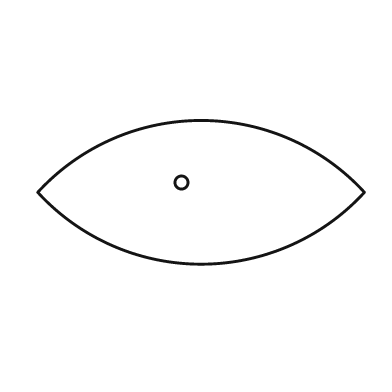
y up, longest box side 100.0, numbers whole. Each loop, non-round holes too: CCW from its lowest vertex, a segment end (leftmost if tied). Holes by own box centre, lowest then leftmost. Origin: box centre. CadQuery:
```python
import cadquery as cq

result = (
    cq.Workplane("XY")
    .moveTo(-50.0, 0.0)
    .threePointArc((0.0, -22.0), (50.0, 0.0))
    .threePointArc((0.0, 22.0), (-50.0, 0.0))
    .close()
    .moveTo(-6.0, 3.0)
    .circle(2.0)
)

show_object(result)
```